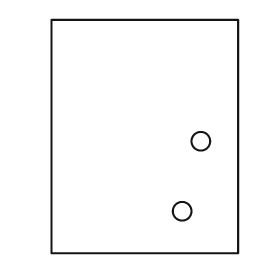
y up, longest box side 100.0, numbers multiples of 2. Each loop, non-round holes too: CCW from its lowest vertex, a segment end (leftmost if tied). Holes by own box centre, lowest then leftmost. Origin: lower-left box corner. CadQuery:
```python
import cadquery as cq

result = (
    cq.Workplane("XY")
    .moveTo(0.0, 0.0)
    .lineTo(80.0, 0.0)
    .lineTo(80.0, 100.0)
    .lineTo(0.0, 100.0)
    .close()
    .moveTo(56.0, 18.0)
    .circle(4.0)
    .moveTo(64.0, 48.0)
    .circle(4.0)
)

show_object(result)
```